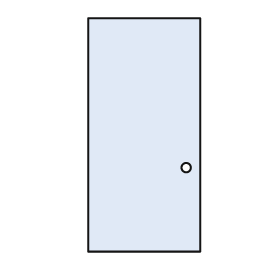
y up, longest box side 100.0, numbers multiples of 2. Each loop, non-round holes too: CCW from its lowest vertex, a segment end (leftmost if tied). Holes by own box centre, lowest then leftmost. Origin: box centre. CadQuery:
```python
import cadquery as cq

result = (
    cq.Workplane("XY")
    .moveTo(-24.0, -50.0)
    .lineTo(24.0, -50.0)
    .lineTo(24.0, 50.0)
    .lineTo(-24.0, 50.0)
    .close()
    .moveTo(18.0, -14.0)
    .circle(2.0)
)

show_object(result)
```